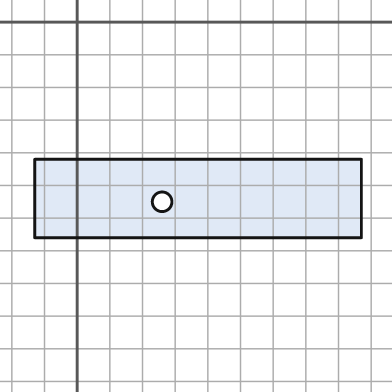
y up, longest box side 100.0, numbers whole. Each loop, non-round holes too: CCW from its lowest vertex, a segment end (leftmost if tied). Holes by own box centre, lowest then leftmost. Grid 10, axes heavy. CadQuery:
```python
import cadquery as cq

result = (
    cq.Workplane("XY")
    .moveTo(-13.0, -66.0)
    .lineTo(87.0, -66.0)
    .lineTo(87.0, -42.0)
    .lineTo(-13.0, -42.0)
    .close()
    .moveTo(26.0, -55.0)
    .circle(3.0)
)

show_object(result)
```